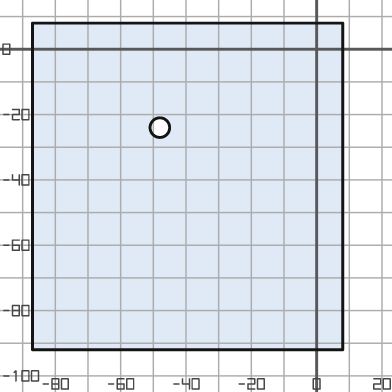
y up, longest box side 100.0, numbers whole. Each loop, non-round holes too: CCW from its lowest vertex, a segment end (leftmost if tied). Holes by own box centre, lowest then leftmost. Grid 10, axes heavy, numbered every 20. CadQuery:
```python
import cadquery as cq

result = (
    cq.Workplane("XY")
    .moveTo(-87.0, -92.0)
    .lineTo(8.0, -92.0)
    .lineTo(8.0, 8.0)
    .lineTo(-87.0, 8.0)
    .close()
    .moveTo(-48.0, -24.0)
    .circle(3.0)
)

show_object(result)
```